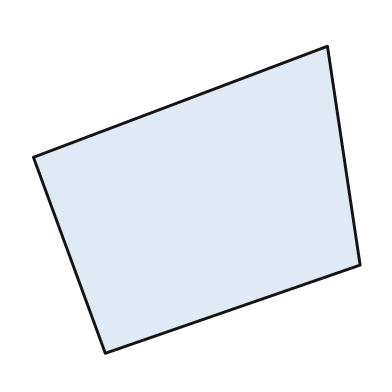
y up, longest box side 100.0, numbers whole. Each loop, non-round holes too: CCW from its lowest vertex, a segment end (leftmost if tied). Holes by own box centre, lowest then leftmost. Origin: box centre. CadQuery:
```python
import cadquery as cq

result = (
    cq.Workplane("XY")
    .moveTo(-28.0, -47.0)
    .lineTo(50.0, -20.0)
    .lineTo(40.0, 47.0)
    .lineTo(-50.0, 13.0)
    .close()
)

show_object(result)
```